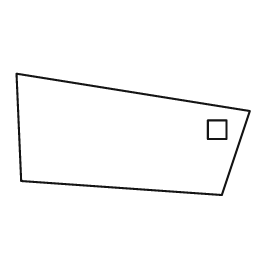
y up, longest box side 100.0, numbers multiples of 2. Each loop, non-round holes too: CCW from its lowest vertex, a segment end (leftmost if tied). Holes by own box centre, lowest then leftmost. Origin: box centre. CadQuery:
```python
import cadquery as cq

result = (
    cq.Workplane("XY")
    .moveTo(38.0, -26.0)
    .lineTo(50.0, 10.0)
    .lineTo(-50.0, 26.0)
    .lineTo(-48.0, -20.0)
    .close()
    .moveTo(32.0, -2.0)
    .lineTo(40.0, -2.0)
    .lineTo(40.0, 6.0)
    .lineTo(32.0, 6.0)
    .close()
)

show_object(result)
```